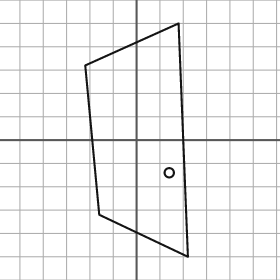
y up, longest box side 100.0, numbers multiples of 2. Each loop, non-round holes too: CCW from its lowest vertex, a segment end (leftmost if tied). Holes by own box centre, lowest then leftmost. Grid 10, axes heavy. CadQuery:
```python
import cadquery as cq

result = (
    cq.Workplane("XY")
    .moveTo(22.0, -50.0)
    .lineTo(18.0, 50.0)
    .lineTo(-22.0, 32.0)
    .lineTo(-16.0, -32.0)
    .close()
    .moveTo(14.0, -14.0)
    .circle(2.0)
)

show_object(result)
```